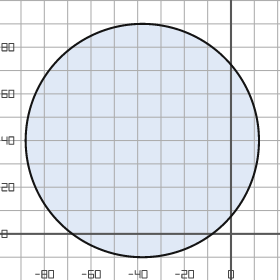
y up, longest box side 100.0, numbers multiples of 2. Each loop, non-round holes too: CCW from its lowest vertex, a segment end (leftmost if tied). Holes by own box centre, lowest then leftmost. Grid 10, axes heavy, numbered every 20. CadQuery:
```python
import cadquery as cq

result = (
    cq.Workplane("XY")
    .moveTo(-38.0, 40.0)
    .circle(50.0)
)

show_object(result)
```